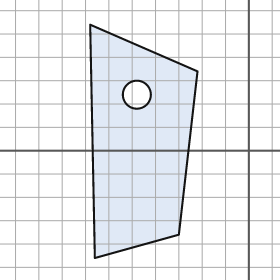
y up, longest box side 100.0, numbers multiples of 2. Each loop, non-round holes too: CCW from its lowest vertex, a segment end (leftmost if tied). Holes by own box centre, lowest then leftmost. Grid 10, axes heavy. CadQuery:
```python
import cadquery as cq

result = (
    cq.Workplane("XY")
    .moveTo(-66.0, -46.0)
    .lineTo(-30.0, -36.0)
    .lineTo(-22.0, 34.0)
    .lineTo(-68.0, 54.0)
    .close()
    .moveTo(-48.0, 24.0)
    .circle(6.0)
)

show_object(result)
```